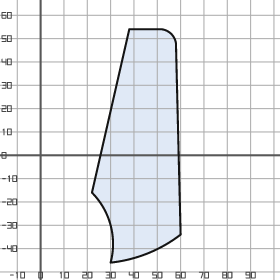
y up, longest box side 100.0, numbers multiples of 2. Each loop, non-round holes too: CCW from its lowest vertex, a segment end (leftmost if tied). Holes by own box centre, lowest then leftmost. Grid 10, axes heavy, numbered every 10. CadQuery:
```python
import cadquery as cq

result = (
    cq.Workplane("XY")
    .moveTo(30.0, -46.0)
    .threePointArc((46.0, -42.0), (60.0, -34.0))
    .lineTo(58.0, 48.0)
    .threePointArc((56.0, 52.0), (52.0, 54.0))
    .lineTo(38.0, 54.0)
    .lineTo(22.0, -16.0)
    .threePointArc((30.0, -30.0), (30.0, -46.0))
    .close()
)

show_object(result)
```